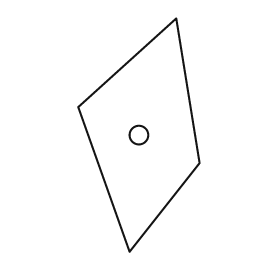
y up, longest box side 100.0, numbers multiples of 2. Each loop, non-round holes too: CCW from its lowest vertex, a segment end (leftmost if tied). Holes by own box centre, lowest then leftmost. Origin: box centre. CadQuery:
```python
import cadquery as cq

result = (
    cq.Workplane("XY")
    .moveTo(-4.0, -50.0)
    .lineTo(26.0, -12.0)
    .lineTo(16.0, 50.0)
    .lineTo(-26.0, 12.0)
    .close()
    .moveTo(0.0, 0.0)
    .circle(4.0)
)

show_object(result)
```